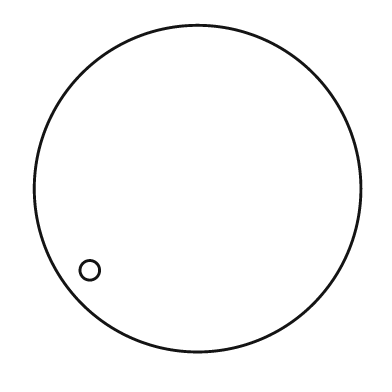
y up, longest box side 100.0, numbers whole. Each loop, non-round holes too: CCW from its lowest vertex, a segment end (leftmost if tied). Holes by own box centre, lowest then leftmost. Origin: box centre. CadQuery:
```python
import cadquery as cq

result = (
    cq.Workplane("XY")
    .moveTo(0.0, 0.0)
    .circle(50.0)
    .moveTo(-33.0, -25.0)
    .circle(3.0)
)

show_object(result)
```